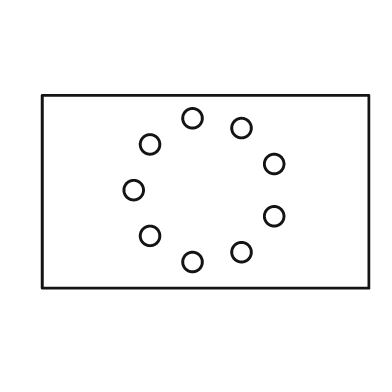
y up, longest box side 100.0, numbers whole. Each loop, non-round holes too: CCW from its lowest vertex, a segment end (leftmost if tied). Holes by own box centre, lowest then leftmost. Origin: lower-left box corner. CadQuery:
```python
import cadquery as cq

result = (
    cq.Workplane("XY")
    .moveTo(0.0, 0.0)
    .lineTo(100.0, 0.0)
    .lineTo(100.0, 59.0)
    .lineTo(0.0, 59.0)
    .close()
    .moveTo(46.0, 8.0)
    .circle(3.0)
    .moveTo(61.0, 11.0)
    .circle(3.0)
    .moveTo(33.0, 16.0)
    .circle(3.0)
    .moveTo(71.0, 22.0)
    .circle(3.0)
    .moveTo(28.0, 30.0)
    .circle(3.0)
    .moveTo(71.0, 38.0)
    .circle(3.0)
    .moveTo(33.0, 44.0)
    .circle(3.0)
    .moveTo(61.0, 49.0)
    .circle(3.0)
    .moveTo(46.0, 52.0)
    .circle(3.0)
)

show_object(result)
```